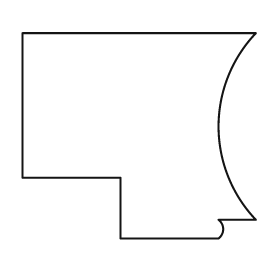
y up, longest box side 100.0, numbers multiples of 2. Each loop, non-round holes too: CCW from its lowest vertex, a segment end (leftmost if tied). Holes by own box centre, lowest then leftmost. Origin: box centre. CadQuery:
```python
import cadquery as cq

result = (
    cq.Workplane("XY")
    .moveTo(-8.0, -44.0)
    .lineTo(34.0, -44.0)
    .threePointArc((36.0, -40.0), (34.0, -36.0))
    .lineTo(50.0, -36.0)
    .threePointArc((34.0, 4.0), (50.0, 44.0))
    .lineTo(-50.0, 44.0)
    .lineTo(-50.0, -18.0)
    .lineTo(-8.0, -18.0)
    .close()
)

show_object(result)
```